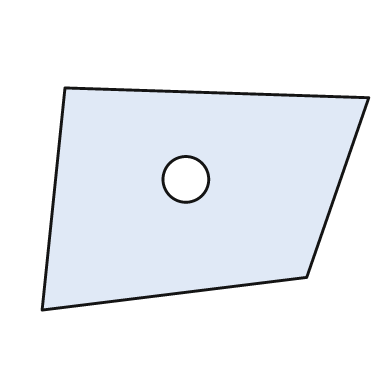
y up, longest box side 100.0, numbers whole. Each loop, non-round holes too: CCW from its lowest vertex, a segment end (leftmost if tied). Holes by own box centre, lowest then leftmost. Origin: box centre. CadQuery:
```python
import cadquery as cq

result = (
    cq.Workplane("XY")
    .moveTo(-50.0, -34.0)
    .lineTo(31.0, -24.0)
    .lineTo(50.0, 31.0)
    .lineTo(-43.0, 34.0)
    .close()
    .moveTo(-6.0, 6.0)
    .circle(7.0)
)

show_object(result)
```